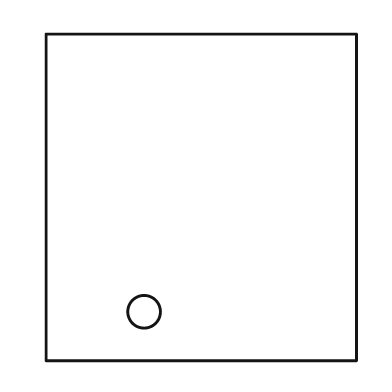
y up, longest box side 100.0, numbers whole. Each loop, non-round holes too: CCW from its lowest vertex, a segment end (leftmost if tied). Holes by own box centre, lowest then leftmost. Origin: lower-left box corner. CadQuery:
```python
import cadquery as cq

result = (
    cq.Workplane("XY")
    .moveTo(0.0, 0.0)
    .lineTo(95.0, 0.0)
    .lineTo(95.0, 100.0)
    .lineTo(0.0, 100.0)
    .close()
    .moveTo(30.0, 15.0)
    .circle(5.0)
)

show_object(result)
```